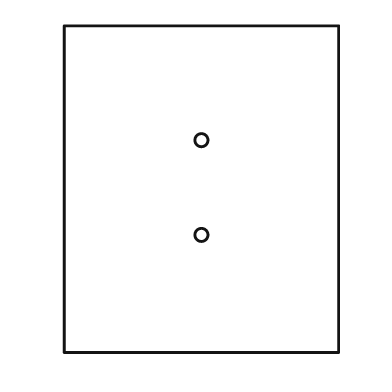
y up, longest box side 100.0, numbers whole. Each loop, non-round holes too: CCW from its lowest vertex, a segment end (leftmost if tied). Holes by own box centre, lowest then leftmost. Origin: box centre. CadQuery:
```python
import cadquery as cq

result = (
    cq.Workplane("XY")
    .moveTo(-42.0, -50.0)
    .lineTo(42.0, -50.0)
    .lineTo(42.0, 50.0)
    .lineTo(-42.0, 50.0)
    .close()
    .moveTo(0.0, -14.0)
    .circle(2.0)
    .moveTo(0.0, 15.0)
    .circle(2.0)
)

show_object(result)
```